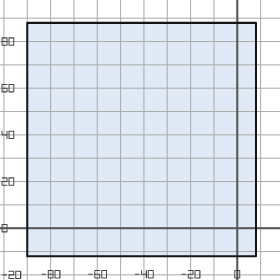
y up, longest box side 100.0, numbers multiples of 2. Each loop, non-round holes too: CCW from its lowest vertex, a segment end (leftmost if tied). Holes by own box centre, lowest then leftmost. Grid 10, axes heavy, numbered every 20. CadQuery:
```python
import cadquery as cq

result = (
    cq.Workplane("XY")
    .moveTo(-90.0, -12.0)
    .lineTo(8.0, -12.0)
    .lineTo(8.0, 88.0)
    .lineTo(-90.0, 88.0)
    .close()
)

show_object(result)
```